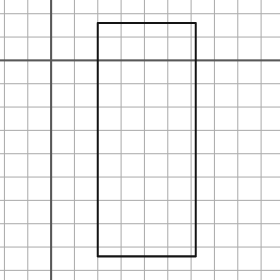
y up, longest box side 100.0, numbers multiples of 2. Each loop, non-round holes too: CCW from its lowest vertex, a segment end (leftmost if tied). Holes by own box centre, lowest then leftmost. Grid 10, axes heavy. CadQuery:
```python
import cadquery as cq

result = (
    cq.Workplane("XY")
    .moveTo(20.0, -84.0)
    .lineTo(62.0, -84.0)
    .lineTo(62.0, 16.0)
    .lineTo(20.0, 16.0)
    .close()
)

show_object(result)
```